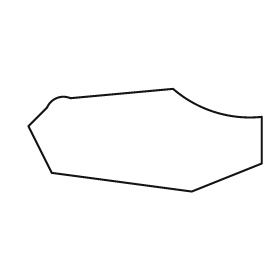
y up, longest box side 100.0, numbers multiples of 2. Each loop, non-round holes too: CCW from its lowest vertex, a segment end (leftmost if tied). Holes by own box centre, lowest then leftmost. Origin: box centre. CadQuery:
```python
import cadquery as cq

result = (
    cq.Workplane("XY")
    .moveTo(20.0, -22.0)
    .lineTo(50.0, -10.0)
    .lineTo(50.0, 10.0)
    .threePointArc((30.0, 12.0), (12.0, 22.0))
    .lineTo(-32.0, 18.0)
    .threePointArc((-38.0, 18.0), (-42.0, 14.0))
    .lineTo(-50.0, 6.0)
    .lineTo(-40.0, -14.0)
    .close()
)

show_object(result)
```